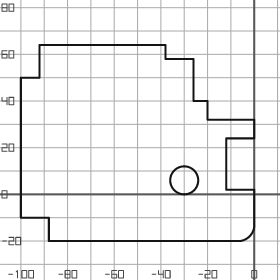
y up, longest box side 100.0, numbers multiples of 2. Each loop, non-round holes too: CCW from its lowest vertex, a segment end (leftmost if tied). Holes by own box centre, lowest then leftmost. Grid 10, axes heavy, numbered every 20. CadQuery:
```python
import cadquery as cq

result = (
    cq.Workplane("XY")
    .moveTo(-88.0, -20.0)
    .lineTo(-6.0, -20.0)
    .threePointArc((-2.0, -18.0), (0.0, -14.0))
    .lineTo(0.0, 2.0)
    .lineTo(-12.0, 2.0)
    .lineTo(-12.0, 24.0)
    .lineTo(0.0, 24.0)
    .lineTo(0.0, 32.0)
    .lineTo(-20.0, 32.0)
    .lineTo(-20.0, 40.0)
    .lineTo(-26.0, 40.0)
    .lineTo(-26.0, 58.0)
    .lineTo(-38.0, 58.0)
    .lineTo(-38.0, 64.0)
    .lineTo(-92.0, 64.0)
    .lineTo(-92.0, 50.0)
    .lineTo(-100.0, 50.0)
    .lineTo(-100.0, -10.0)
    .lineTo(-88.0, -10.0)
    .close()
    .moveTo(-30.0, 6.0)
    .circle(6.0)
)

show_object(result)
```